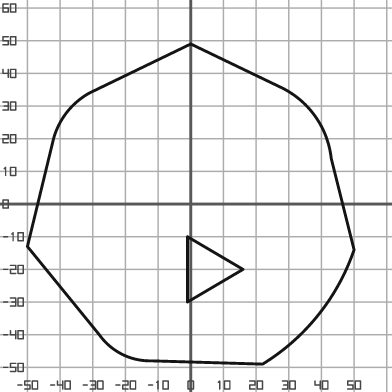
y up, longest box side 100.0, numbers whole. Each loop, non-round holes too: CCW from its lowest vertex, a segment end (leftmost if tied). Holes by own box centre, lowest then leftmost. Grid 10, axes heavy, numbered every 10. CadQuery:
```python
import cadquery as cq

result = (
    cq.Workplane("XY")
    .moveTo(22.0, -49.0)
    .threePointArc((39.0, -34.0), (50.0, -14.0))
    .lineTo(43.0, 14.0)
    .threePointArc((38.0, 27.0), (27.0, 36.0))
    .lineTo(0.0, 49.0)
    .lineTo(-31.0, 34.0)
    .threePointArc((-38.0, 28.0), (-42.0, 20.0))
    .lineTo(-50.0, -13.0)
    .lineTo(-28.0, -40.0)
    .threePointArc((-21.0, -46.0), (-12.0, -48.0))
    .close()
    .moveTo(-1.0, -30.0)
    .lineTo(16.0, -20.0)
    .lineTo(-1.0, -10.0)
    .close()
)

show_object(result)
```